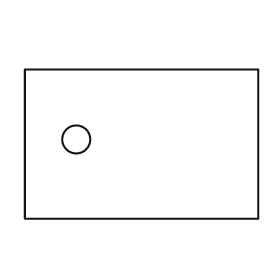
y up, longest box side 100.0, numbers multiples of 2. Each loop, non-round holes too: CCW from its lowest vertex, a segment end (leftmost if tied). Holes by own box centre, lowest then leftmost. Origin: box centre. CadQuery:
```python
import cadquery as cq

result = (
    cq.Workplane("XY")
    .moveTo(-50.0, -32.0)
    .lineTo(50.0, -32.0)
    .lineTo(50.0, 32.0)
    .lineTo(-50.0, 32.0)
    .close()
    .moveTo(-28.0, 2.0)
    .circle(6.0)
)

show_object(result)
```